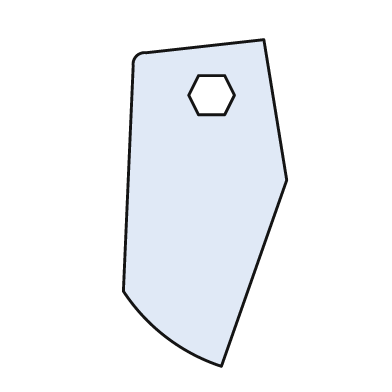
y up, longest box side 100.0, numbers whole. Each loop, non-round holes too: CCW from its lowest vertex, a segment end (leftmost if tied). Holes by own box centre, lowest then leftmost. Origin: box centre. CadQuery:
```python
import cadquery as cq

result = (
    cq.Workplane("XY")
    .moveTo(5.0, -50.0)
    .lineTo(25.0, 7.0)
    .lineTo(18.0, 50.0)
    .lineTo(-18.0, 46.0)
    .threePointArc((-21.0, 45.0), (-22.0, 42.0))
    .lineTo(-25.0, -27.0)
    .threePointArc((-12.0, -41.0), (5.0, -50.0))
    .close()
    .moveTo(-2.0, 27.0)
    .lineTo(6.0, 27.0)
    .lineTo(9.0, 33.0)
    .lineTo(6.0, 39.0)
    .lineTo(-2.0, 39.0)
    .lineTo(-5.0, 33.0)
    .close()
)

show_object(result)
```